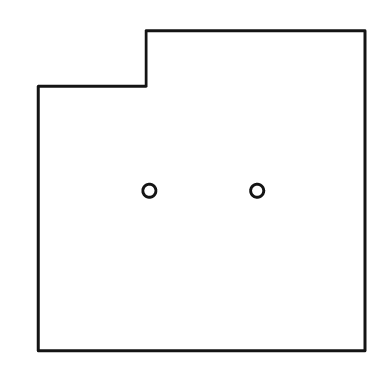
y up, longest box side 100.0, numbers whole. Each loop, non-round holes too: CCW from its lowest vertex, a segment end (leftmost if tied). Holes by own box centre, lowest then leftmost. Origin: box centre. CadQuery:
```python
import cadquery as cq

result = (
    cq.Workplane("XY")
    .moveTo(-50.0, -49.0)
    .lineTo(50.0, -49.0)
    .lineTo(50.0, 49.0)
    .lineTo(-17.0, 49.0)
    .lineTo(-17.0, 32.0)
    .lineTo(-50.0, 32.0)
    .close()
    .moveTo(-16.0, 0.0)
    .circle(2.0)
    .moveTo(17.0, 0.0)
    .circle(2.0)
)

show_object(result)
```